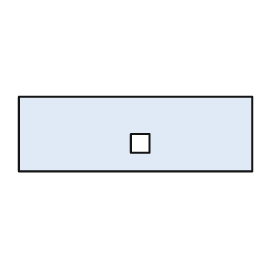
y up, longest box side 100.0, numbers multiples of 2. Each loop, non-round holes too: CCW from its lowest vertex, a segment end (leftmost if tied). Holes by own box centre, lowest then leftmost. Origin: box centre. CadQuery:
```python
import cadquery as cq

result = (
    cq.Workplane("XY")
    .moveTo(-50.0, -16.0)
    .lineTo(50.0, -16.0)
    .lineTo(50.0, 16.0)
    .lineTo(-50.0, 16.0)
    .close()
    .moveTo(-2.0, -8.0)
    .lineTo(6.0, -8.0)
    .lineTo(6.0, 0.0)
    .lineTo(-2.0, 0.0)
    .close()
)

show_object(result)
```